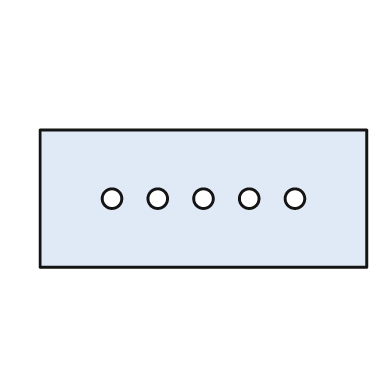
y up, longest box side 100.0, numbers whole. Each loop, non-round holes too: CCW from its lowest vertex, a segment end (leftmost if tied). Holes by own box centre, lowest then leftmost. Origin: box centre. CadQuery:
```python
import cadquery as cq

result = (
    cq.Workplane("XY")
    .moveTo(-50.0, -21.0)
    .lineTo(50.0, -21.0)
    .lineTo(50.0, 21.0)
    .lineTo(-50.0, 21.0)
    .close()
    .moveTo(-28.0, 0.0)
    .circle(3.0)
    .moveTo(-14.0, 0.0)
    .circle(3.0)
    .moveTo(0.0, 0.0)
    .circle(3.0)
    .moveTo(14.0, 0.0)
    .circle(3.0)
    .moveTo(28.0, 0.0)
    .circle(3.0)
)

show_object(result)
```